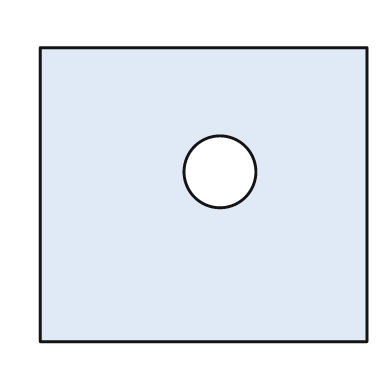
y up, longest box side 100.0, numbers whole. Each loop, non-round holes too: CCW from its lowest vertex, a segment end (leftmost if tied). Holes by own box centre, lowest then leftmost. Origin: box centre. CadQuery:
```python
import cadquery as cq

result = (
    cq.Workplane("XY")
    .moveTo(-50.0, -45.0)
    .lineTo(50.0, -45.0)
    .lineTo(50.0, 45.0)
    .lineTo(-50.0, 45.0)
    .close()
    .moveTo(5.0, 7.0)
    .circle(11.0)
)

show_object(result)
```